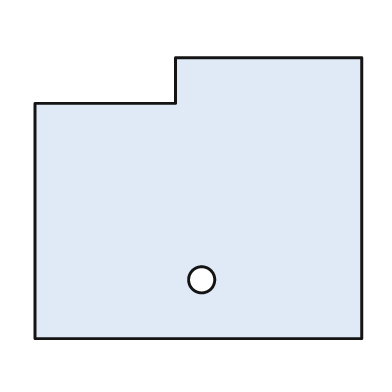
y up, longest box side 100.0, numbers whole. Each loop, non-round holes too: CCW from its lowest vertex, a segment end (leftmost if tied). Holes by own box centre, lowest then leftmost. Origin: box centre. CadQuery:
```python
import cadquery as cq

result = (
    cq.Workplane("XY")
    .moveTo(-50.0, -43.0)
    .lineTo(50.0, -43.0)
    .lineTo(50.0, 43.0)
    .lineTo(-7.0, 43.0)
    .lineTo(-7.0, 29.0)
    .lineTo(-50.0, 29.0)
    .close()
    .moveTo(1.0, -25.0)
    .circle(4.0)
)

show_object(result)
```